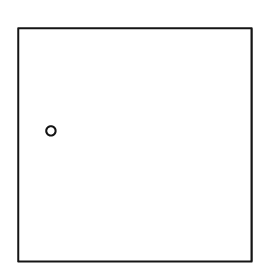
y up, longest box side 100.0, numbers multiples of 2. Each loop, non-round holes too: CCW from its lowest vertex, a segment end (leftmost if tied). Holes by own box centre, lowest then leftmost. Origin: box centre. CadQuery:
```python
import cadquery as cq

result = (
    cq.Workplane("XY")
    .moveTo(-50.0, -50.0)
    .lineTo(50.0, -50.0)
    .lineTo(50.0, 50.0)
    .lineTo(-50.0, 50.0)
    .close()
    .moveTo(-36.0, 6.0)
    .circle(2.0)
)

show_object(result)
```